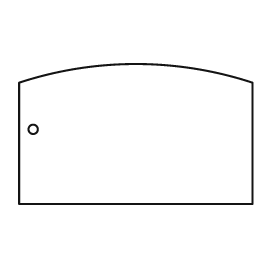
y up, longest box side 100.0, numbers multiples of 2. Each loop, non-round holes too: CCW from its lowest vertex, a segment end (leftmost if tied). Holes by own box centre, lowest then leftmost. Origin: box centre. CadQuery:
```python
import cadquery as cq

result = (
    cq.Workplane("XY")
    .moveTo(-50.0, -30.0)
    .lineTo(50.0, -30.0)
    .lineTo(50.0, 22.0)
    .threePointArc((0.0, 30.0), (-50.0, 22.0))
    .close()
    .moveTo(-44.0, 2.0)
    .circle(2.0)
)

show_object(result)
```